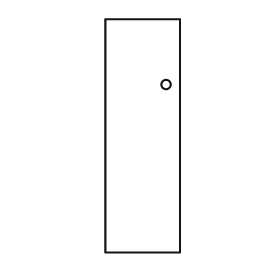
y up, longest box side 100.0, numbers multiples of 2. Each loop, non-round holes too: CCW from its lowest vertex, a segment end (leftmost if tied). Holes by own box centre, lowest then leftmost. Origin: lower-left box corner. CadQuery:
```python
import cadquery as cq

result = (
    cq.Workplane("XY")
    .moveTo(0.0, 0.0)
    .lineTo(32.0, 0.0)
    .lineTo(32.0, 100.0)
    .lineTo(0.0, 100.0)
    .close()
    .moveTo(26.0, 72.0)
    .circle(2.0)
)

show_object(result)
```